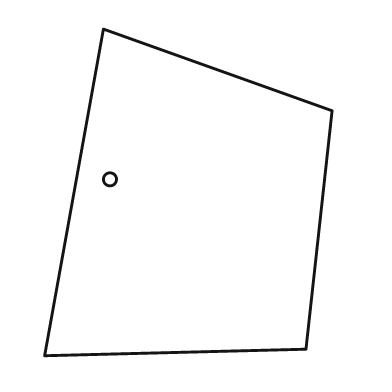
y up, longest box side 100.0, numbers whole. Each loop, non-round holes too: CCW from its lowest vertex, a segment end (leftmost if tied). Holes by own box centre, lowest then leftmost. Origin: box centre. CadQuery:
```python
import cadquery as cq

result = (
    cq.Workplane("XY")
    .moveTo(-44.0, -50.0)
    .lineTo(36.0, -48.0)
    .lineTo(44.0, 25.0)
    .lineTo(-26.0, 50.0)
    .close()
    .moveTo(-24.0, 4.0)
    .circle(2.0)
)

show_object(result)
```